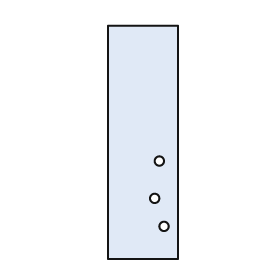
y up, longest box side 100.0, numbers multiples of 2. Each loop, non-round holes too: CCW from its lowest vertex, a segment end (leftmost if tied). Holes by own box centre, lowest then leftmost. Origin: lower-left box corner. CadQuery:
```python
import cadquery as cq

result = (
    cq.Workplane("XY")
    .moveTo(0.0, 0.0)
    .lineTo(30.0, 0.0)
    .lineTo(30.0, 100.0)
    .lineTo(0.0, 100.0)
    .close()
    .moveTo(24.0, 14.0)
    .circle(2.0)
    .moveTo(20.0, 26.0)
    .circle(2.0)
    .moveTo(22.0, 42.0)
    .circle(2.0)
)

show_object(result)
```